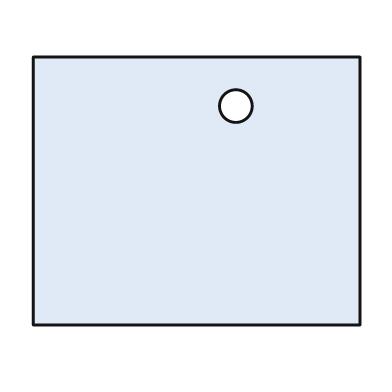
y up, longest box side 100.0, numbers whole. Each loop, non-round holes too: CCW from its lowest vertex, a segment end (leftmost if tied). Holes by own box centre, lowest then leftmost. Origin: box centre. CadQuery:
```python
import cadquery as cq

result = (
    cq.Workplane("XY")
    .moveTo(-50.0, -41.0)
    .lineTo(50.0, -41.0)
    .lineTo(50.0, 41.0)
    .lineTo(-50.0, 41.0)
    .close()
    .moveTo(12.0, 26.0)
    .circle(5.0)
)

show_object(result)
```